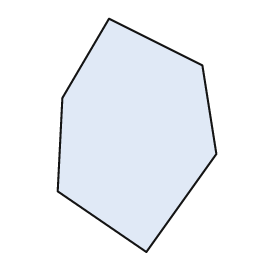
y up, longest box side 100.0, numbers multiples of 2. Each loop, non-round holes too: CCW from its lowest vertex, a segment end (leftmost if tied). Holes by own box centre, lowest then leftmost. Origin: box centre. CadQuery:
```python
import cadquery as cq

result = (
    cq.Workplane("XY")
    .moveTo(4.0, -50.0)
    .lineTo(34.0, -8.0)
    .lineTo(28.0, 30.0)
    .lineTo(-12.0, 50.0)
    .lineTo(-32.0, 16.0)
    .lineTo(-34.0, -24.0)
    .close()
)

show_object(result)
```